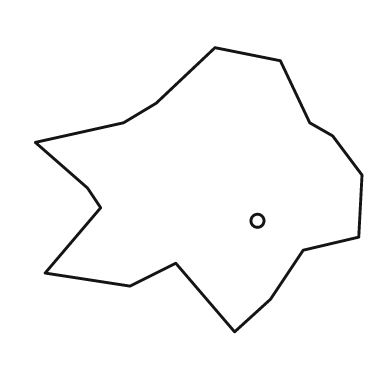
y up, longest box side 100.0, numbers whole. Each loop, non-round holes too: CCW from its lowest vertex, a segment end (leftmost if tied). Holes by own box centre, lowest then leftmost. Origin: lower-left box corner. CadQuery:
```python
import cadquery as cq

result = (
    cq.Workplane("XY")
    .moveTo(61.0, 0.0)
    .lineTo(72.0, 10.0)
    .lineTo(82.0, 25.0)
    .lineTo(99.0, 29.0)
    .lineTo(100.0, 48.0)
    .lineTo(91.0, 60.0)
    .lineTo(84.0, 64.0)
    .lineTo(75.0, 83.0)
    .lineTo(55.0, 87.0)
    .lineTo(37.0, 70.0)
    .lineTo(27.0, 64.0)
    .lineTo(0.0, 58.0)
    .lineTo(16.0, 44.0)
    .lineTo(20.0, 38.0)
    .lineTo(3.0, 18.0)
    .lineTo(29.0, 14.0)
    .lineTo(43.0, 21.0)
    .close()
    .moveTo(68.0, 34.0)
    .circle(2.0)
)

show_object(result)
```